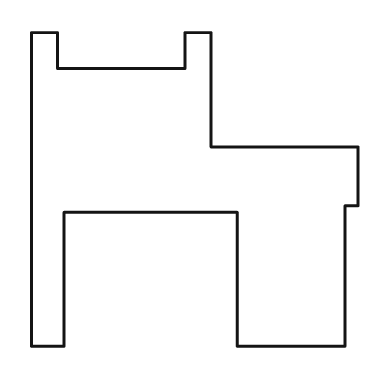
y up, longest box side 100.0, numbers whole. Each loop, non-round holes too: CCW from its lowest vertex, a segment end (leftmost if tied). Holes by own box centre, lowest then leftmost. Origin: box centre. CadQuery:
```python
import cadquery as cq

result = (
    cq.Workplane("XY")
    .moveTo(-50.0, -48.0)
    .lineTo(-40.0, -48.0)
    .lineTo(-40.0, -7.0)
    .lineTo(13.0, -7.0)
    .lineTo(13.0, -48.0)
    .lineTo(46.0, -48.0)
    .lineTo(46.0, -5.0)
    .lineTo(50.0, -5.0)
    .lineTo(50.0, 13.0)
    .lineTo(5.0, 13.0)
    .lineTo(5.0, 48.0)
    .lineTo(-3.0, 48.0)
    .lineTo(-3.0, 37.0)
    .lineTo(-42.0, 37.0)
    .lineTo(-42.0, 48.0)
    .lineTo(-50.0, 48.0)
    .close()
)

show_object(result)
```